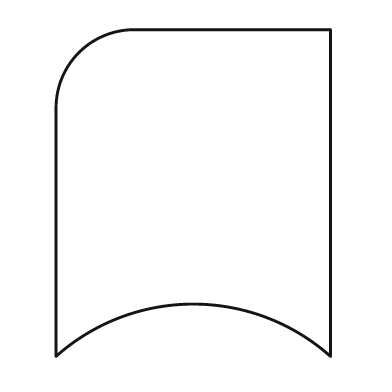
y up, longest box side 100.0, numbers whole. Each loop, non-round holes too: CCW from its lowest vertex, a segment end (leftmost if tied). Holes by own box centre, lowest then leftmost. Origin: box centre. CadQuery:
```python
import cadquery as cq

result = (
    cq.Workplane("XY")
    .moveTo(-42.0, -50.0)
    .threePointArc((0.0, -34.0), (42.0, -50.0))
    .lineTo(42.0, 50.0)
    .lineTo(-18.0, 50.0)
    .threePointArc((-35.0, 43.0), (-42.0, 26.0))
    .close()
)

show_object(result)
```